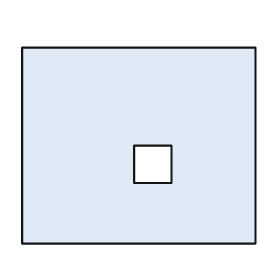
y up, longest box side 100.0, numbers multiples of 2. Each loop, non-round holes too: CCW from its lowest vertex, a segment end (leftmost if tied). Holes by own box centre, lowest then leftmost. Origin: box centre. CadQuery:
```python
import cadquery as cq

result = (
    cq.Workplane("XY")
    .moveTo(-50.0, -42.0)
    .lineTo(50.0, -42.0)
    .lineTo(50.0, 42.0)
    .lineTo(-50.0, 42.0)
    .close()
    .moveTo(-2.0, -16.0)
    .lineTo(14.0, -16.0)
    .lineTo(14.0, 0.0)
    .lineTo(-2.0, 0.0)
    .close()
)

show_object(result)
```